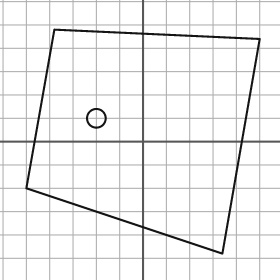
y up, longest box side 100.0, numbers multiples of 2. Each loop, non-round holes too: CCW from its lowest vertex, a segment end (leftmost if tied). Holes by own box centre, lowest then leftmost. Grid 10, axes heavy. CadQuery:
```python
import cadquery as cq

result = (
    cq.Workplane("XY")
    .moveTo(34.0, -48.0)
    .lineTo(50.0, 44.0)
    .lineTo(-38.0, 48.0)
    .lineTo(-50.0, -20.0)
    .close()
    .moveTo(-20.0, 10.0)
    .circle(4.0)
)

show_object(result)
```